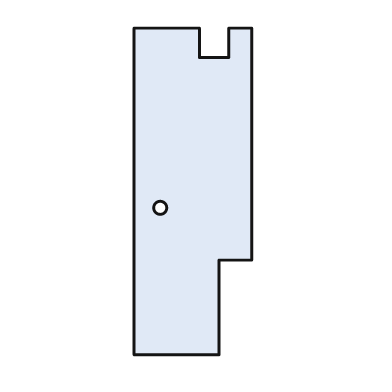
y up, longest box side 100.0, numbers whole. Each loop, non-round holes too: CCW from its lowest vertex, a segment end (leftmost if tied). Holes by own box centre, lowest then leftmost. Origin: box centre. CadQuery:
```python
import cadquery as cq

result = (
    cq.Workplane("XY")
    .moveTo(-18.0, -50.0)
    .lineTo(8.0, -50.0)
    .lineTo(8.0, -21.0)
    .lineTo(18.0, -21.0)
    .lineTo(18.0, 50.0)
    .lineTo(11.0, 50.0)
    .lineTo(11.0, 41.0)
    .lineTo(2.0, 41.0)
    .lineTo(2.0, 50.0)
    .lineTo(-18.0, 50.0)
    .close()
    .moveTo(-10.0, -5.0)
    .circle(2.0)
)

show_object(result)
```